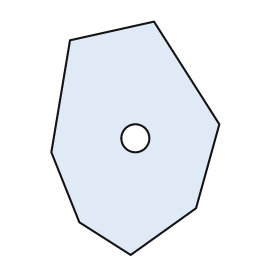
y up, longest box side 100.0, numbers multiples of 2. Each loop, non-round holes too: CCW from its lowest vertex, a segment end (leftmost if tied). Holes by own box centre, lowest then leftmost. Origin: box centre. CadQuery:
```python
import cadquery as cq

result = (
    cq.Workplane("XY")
    .moveTo(-2.0, -50.0)
    .lineTo(26.0, -30.0)
    .lineTo(36.0, 6.0)
    .lineTo(8.0, 50.0)
    .lineTo(-28.0, 42.0)
    .lineTo(-36.0, -6.0)
    .lineTo(-24.0, -36.0)
    .close()
    .moveTo(0.0, 0.0)
    .circle(6.0)
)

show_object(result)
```